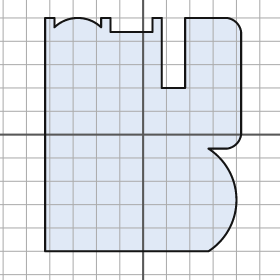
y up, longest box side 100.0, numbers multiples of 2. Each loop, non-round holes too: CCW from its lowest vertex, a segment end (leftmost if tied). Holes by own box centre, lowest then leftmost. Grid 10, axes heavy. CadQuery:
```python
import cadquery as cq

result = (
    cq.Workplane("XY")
    .moveTo(-42.0, -50.0)
    .lineTo(28.0, -50.0)
    .threePointArc((40.0, -28.0), (28.0, -6.0))
    .lineTo(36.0, -6.0)
    .threePointArc((40.0, -4.0), (42.0, 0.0))
    .lineTo(42.0, 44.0)
    .threePointArc((40.0, 48.0), (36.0, 50.0))
    .lineTo(18.0, 50.0)
    .lineTo(18.0, 20.0)
    .lineTo(8.0, 20.0)
    .lineTo(8.0, 50.0)
    .lineTo(4.0, 50.0)
    .lineTo(4.0, 44.0)
    .lineTo(-14.0, 44.0)
    .lineTo(-14.0, 50.0)
    .lineTo(-18.0, 50.0)
    .lineTo(-18.0, 46.0)
    .threePointArc((-28.0, 50.0), (-38.0, 46.0))
    .lineTo(-38.0, 50.0)
    .lineTo(-42.0, 50.0)
    .close()
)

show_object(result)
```